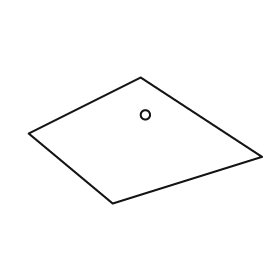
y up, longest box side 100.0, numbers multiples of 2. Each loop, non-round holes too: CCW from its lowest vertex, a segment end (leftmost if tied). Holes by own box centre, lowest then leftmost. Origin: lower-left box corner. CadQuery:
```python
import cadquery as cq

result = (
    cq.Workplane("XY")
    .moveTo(36.0, 0.0)
    .lineTo(100.0, 20.0)
    .lineTo(48.0, 54.0)
    .lineTo(0.0, 30.0)
    .close()
    .moveTo(50.0, 38.0)
    .circle(2.0)
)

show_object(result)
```